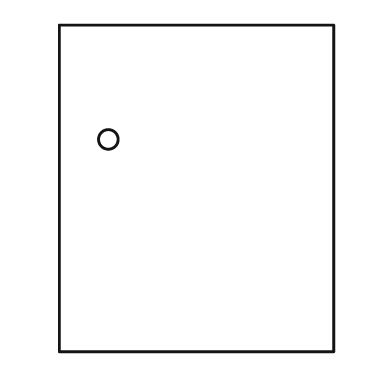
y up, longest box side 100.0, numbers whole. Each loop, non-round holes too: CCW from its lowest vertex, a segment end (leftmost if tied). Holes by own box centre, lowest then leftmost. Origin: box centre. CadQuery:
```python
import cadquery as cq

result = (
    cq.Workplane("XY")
    .moveTo(-42.0, -50.0)
    .lineTo(42.0, -50.0)
    .lineTo(42.0, 50.0)
    .lineTo(-42.0, 50.0)
    .close()
    .moveTo(-27.0, 15.0)
    .circle(3.0)
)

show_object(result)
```